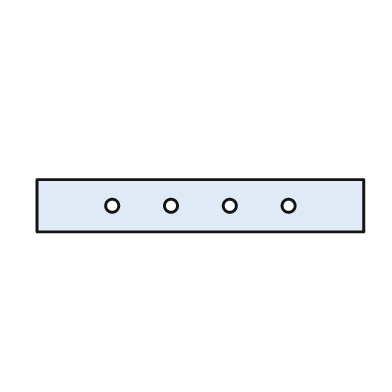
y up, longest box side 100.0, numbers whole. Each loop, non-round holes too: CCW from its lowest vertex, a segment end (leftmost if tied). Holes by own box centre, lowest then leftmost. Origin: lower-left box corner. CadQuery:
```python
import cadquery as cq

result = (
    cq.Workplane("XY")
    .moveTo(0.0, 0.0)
    .lineTo(100.0, 0.0)
    .lineTo(100.0, 16.0)
    .lineTo(0.0, 16.0)
    .close()
    .moveTo(23.0, 8.0)
    .circle(2.0)
    .moveTo(41.0, 8.0)
    .circle(2.0)
    .moveTo(59.0, 8.0)
    .circle(2.0)
    .moveTo(77.0, 8.0)
    .circle(2.0)
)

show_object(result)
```